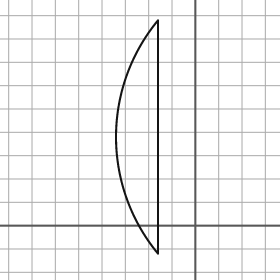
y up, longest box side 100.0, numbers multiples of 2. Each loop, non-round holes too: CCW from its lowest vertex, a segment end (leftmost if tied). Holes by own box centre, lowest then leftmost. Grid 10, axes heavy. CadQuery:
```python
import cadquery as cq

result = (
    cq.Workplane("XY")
    .moveTo(-16.0, -12.0)
    .lineTo(-16.0, 88.0)
    .threePointArc((-34.0, 38.0), (-16.0, -12.0))
    .close()
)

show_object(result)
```